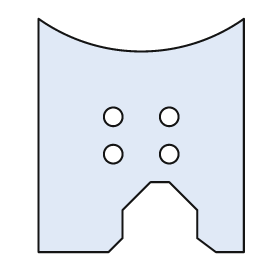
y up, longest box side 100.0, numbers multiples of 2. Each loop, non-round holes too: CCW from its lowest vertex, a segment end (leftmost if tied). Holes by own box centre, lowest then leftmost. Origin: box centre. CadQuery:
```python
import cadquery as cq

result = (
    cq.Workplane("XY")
    .moveTo(-44.0, -50.0)
    .lineTo(-14.0, -50.0)
    .lineTo(-8.0, -44.0)
    .lineTo(-8.0, -32.0)
    .lineTo(4.0, -20.0)
    .lineTo(12.0, -20.0)
    .lineTo(24.0, -32.0)
    .lineTo(24.0, -44.0)
    .lineTo(32.0, -50.0)
    .lineTo(44.0, -50.0)
    .lineTo(44.0, 50.0)
    .threePointArc((0.0, 36.0), (-44.0, 50.0))
    .close()
    .moveTo(-12.0, -8.0)
    .circle(4.0)
    .moveTo(12.0, -8.0)
    .circle(4.0)
    .moveTo(-12.0, 8.0)
    .circle(4.0)
    .moveTo(12.0, 8.0)
    .circle(4.0)
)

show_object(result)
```